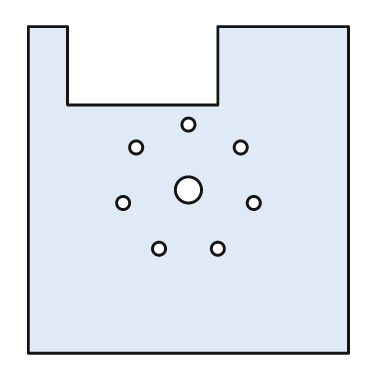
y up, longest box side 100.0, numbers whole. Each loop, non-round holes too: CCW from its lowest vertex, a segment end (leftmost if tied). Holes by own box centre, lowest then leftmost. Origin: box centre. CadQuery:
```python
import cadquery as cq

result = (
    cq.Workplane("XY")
    .moveTo(-49.0, -50.0)
    .lineTo(49.0, -50.0)
    .lineTo(49.0, 50.0)
    .lineTo(9.0, 50.0)
    .lineTo(9.0, 26.0)
    .lineTo(-37.0, 26.0)
    .lineTo(-37.0, 50.0)
    .lineTo(-49.0, 50.0)
    .close()
    .moveTo(-9.0, -18.0)
    .circle(2.0)
    .moveTo(9.0, -18.0)
    .circle(2.0)
    .moveTo(-20.0, -4.0)
    .circle(2.0)
    .moveTo(20.0, -4.0)
    .circle(2.0)
    .moveTo(0.0, 0.0)
    .circle(4.0)
    .moveTo(-16.0, 13.0)
    .circle(2.0)
    .moveTo(16.0, 13.0)
    .circle(2.0)
    .moveTo(0.0, 20.0)
    .circle(2.0)
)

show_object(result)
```